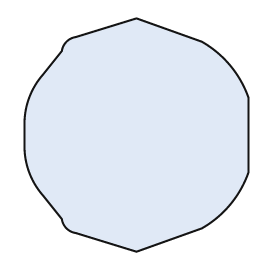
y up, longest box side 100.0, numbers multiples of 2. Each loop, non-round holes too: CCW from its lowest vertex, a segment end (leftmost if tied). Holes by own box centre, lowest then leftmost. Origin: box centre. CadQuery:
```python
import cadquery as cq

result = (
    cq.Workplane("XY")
    .moveTo(0.0, -50.0)
    .lineTo(28.0, -40.0)
    .threePointArc((40.0, -30.0), (48.0, -16.0))
    .lineTo(48.0, 16.0)
    .threePointArc((40.0, 30.0), (28.0, 40.0))
    .lineTo(0.0, 50.0)
    .lineTo(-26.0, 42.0)
    .threePointArc((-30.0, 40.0), (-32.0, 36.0))
    .lineTo(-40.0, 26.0)
    .threePointArc((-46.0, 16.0), (-48.0, 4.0))
    .lineTo(-48.0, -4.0)
    .threePointArc((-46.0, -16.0), (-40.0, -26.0))
    .lineTo(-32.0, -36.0)
    .threePointArc((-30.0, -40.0), (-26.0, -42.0))
    .close()
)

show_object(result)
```